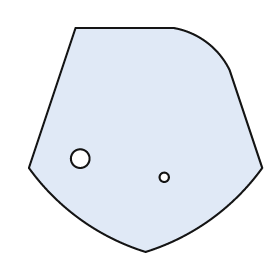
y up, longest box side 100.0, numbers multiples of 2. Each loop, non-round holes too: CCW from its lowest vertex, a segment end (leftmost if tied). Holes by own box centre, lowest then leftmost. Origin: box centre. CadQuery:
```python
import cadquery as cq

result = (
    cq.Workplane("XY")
    .moveTo(0.0, -48.0)
    .threePointArc((28.0, -34.0), (50.0, -12.0))
    .lineTo(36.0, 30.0)
    .threePointArc((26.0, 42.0), (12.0, 48.0))
    .lineTo(-30.0, 48.0)
    .lineTo(-50.0, -12.0)
    .threePointArc((-28.0, -34.0), (0.0, -48.0))
    .close()
    .moveTo(8.0, -16.0)
    .circle(2.0)
    .moveTo(-28.0, -8.0)
    .circle(4.0)
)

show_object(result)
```